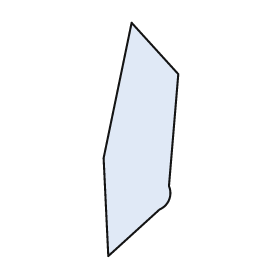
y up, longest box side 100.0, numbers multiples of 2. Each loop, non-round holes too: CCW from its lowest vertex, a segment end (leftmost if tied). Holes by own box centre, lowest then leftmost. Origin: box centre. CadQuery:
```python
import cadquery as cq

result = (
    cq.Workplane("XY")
    .moveTo(-14.0, -50.0)
    .lineTo(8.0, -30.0)
    .threePointArc((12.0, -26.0), (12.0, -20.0))
    .lineTo(16.0, 28.0)
    .lineTo(-4.0, 50.0)
    .lineTo(-16.0, -8.0)
    .close()
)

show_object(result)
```